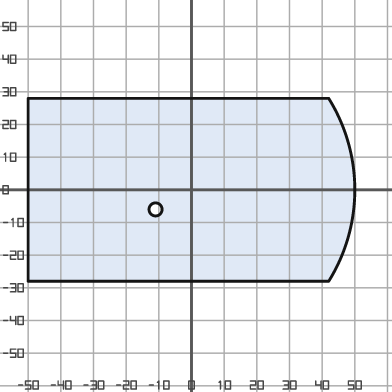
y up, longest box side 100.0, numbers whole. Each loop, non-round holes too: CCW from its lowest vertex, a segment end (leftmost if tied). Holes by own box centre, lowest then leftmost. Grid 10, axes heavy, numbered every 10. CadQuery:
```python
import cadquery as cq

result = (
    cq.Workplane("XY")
    .moveTo(-50.0, -28.0)
    .lineTo(42.0, -28.0)
    .threePointArc((50.0, 0.0), (42.0, 28.0))
    .lineTo(-50.0, 28.0)
    .close()
    .moveTo(-11.0, -6.0)
    .circle(2.0)
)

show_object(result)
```